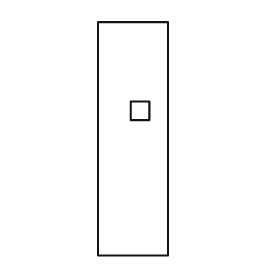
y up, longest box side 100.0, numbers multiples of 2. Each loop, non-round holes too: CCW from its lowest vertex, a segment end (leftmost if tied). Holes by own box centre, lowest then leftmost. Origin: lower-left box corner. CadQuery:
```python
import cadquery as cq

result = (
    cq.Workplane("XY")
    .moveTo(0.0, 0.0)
    .lineTo(30.0, 0.0)
    .lineTo(30.0, 100.0)
    .lineTo(0.0, 100.0)
    .close()
    .moveTo(14.0, 58.0)
    .lineTo(22.0, 58.0)
    .lineTo(22.0, 66.0)
    .lineTo(14.0, 66.0)
    .close()
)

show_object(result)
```